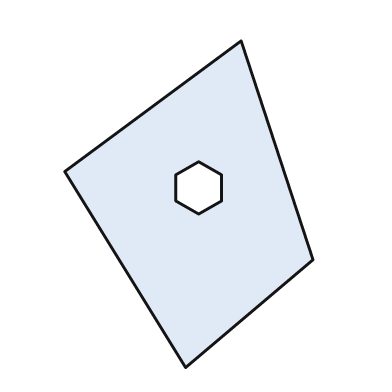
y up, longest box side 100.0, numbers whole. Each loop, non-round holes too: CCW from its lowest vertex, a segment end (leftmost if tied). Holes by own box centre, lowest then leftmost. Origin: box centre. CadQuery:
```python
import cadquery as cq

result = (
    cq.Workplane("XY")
    .moveTo(-1.0, -50.0)
    .lineTo(38.0, -17.0)
    .lineTo(16.0, 50.0)
    .lineTo(-38.0, 10.0)
    .close()
    .moveTo(3.0, -3.0)
    .lineTo(10.0, 1.0)
    .lineTo(10.0, 9.0)
    .lineTo(3.0, 13.0)
    .lineTo(-4.0, 9.0)
    .lineTo(-4.0, 1.0)
    .close()
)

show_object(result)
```